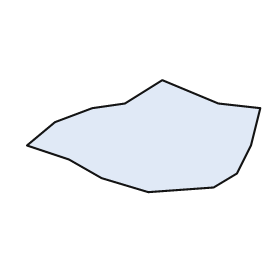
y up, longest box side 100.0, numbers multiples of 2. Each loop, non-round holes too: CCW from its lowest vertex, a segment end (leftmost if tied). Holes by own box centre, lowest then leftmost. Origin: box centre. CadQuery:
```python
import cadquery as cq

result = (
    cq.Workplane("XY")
    .moveTo(2.0, -24.0)
    .lineTo(30.0, -22.0)
    .lineTo(40.0, -16.0)
    .lineTo(46.0, -4.0)
    .lineTo(50.0, 12.0)
    .lineTo(32.0, 14.0)
    .lineTo(8.0, 24.0)
    .lineTo(-8.0, 14.0)
    .lineTo(-22.0, 12.0)
    .lineTo(-38.0, 6.0)
    .lineTo(-50.0, -4.0)
    .lineTo(-32.0, -10.0)
    .lineTo(-18.0, -18.0)
    .close()
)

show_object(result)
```